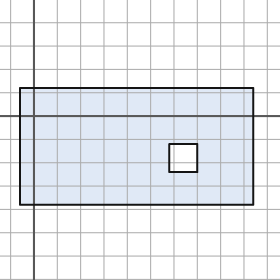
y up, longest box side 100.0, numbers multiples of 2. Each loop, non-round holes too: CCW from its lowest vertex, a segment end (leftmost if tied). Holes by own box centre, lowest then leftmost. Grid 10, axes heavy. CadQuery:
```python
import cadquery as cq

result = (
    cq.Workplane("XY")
    .moveTo(-6.0, -38.0)
    .lineTo(94.0, -38.0)
    .lineTo(94.0, 12.0)
    .lineTo(-6.0, 12.0)
    .close()
    .moveTo(58.0, -24.0)
    .lineTo(70.0, -24.0)
    .lineTo(70.0, -12.0)
    .lineTo(58.0, -12.0)
    .close()
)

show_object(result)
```